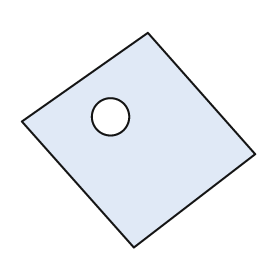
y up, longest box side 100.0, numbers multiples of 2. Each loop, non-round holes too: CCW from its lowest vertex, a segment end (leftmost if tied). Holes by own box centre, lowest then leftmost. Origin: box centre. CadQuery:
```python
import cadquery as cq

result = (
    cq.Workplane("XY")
    .moveTo(-2.0, -46.0)
    .lineTo(50.0, -6.0)
    .lineTo(4.0, 46.0)
    .lineTo(-50.0, 8.0)
    .close()
    .moveTo(-12.0, 10.0)
    .circle(8.0)
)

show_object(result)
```